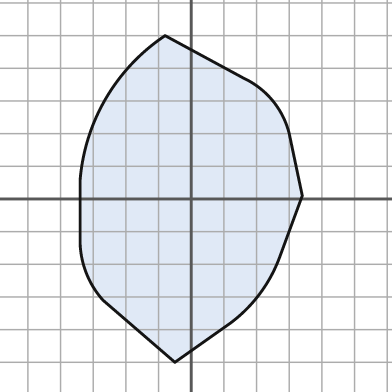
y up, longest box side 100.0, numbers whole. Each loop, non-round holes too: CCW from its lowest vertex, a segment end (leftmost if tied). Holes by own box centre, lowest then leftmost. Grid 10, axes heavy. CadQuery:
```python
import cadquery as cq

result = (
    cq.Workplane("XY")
    .moveTo(-5.0, -50.0)
    .lineTo(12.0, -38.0)
    .threePointArc((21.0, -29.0), (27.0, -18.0))
    .lineTo(34.0, 1.0)
    .lineTo(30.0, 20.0)
    .threePointArc((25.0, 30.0), (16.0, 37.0))
    .lineTo(-8.0, 50.0)
    .threePointArc((-26.0, 31.0), (-34.0, 6.0))
    .lineTo(-34.0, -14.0)
    .threePointArc((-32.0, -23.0), (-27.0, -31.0))
    .close()
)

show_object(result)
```